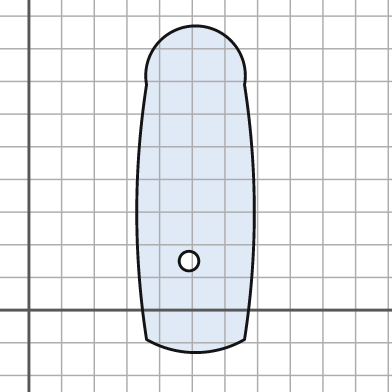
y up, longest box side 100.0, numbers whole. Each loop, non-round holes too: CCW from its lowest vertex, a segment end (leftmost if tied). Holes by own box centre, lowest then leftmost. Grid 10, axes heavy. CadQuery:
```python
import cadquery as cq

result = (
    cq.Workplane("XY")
    .moveTo(36.0, -9.0)
    .threePointArc((51.0, -13.0), (66.0, -9.0))
    .threePointArc((69.0, 30.0), (66.0, 69.0))
    .threePointArc((51.0, 87.0), (36.0, 69.0))
    .threePointArc((33.0, 30.0), (36.0, -9.0))
    .close()
    .moveTo(49.0, 15.0)
    .circle(3.0)
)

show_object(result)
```